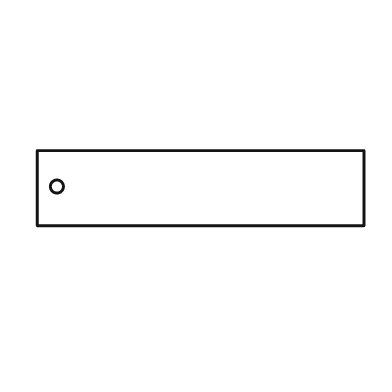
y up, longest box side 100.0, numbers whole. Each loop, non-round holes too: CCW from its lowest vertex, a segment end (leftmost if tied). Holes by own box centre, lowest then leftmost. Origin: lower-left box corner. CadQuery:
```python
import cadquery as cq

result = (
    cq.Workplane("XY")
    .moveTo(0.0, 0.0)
    .lineTo(100.0, 0.0)
    .lineTo(100.0, 23.0)
    .lineTo(0.0, 23.0)
    .close()
    .moveTo(6.0, 12.0)
    .circle(2.0)
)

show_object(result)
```